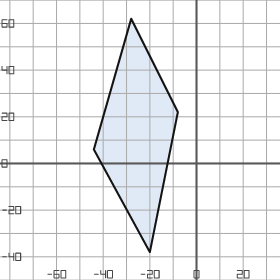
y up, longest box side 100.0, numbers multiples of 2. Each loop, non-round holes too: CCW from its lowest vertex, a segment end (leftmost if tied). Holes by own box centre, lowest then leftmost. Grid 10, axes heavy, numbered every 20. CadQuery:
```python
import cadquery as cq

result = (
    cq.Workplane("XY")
    .moveTo(-20.0, -38.0)
    .lineTo(-8.0, 22.0)
    .lineTo(-28.0, 62.0)
    .lineTo(-44.0, 6.0)
    .close()
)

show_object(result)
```